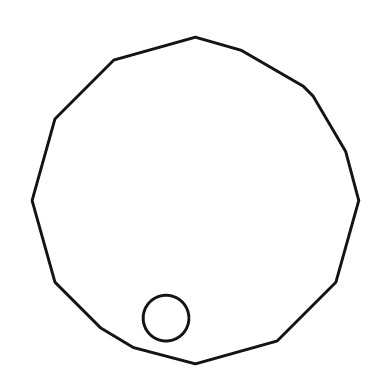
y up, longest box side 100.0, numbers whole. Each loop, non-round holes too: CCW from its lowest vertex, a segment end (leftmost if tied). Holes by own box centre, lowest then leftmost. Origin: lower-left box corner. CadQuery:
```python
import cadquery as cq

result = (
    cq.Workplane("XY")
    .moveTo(50.0, 0.0)
    .lineTo(75.0, 7.0)
    .lineTo(93.0, 25.0)
    .lineTo(100.0, 50.0)
    .lineTo(96.0, 65.0)
    .lineTo(86.0, 82.0)
    .lineTo(83.0, 85.0)
    .lineTo(64.0, 96.0)
    .lineTo(50.0, 100.0)
    .lineTo(25.0, 93.0)
    .lineTo(7.0, 75.0)
    .lineTo(0.0, 50.0)
    .lineTo(7.0, 25.0)
    .lineTo(21.0, 11.0)
    .lineTo(31.0, 5.0)
    .close()
    .moveTo(41.0, 14.0)
    .circle(7.0)
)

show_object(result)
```